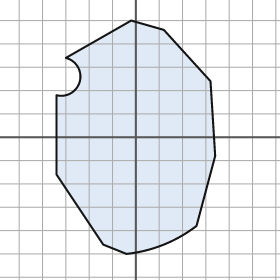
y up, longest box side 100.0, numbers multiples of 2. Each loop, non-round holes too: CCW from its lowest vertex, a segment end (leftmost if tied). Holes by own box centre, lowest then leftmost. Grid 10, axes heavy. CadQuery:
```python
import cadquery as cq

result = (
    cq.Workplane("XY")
    .moveTo(-4.0, -50.0)
    .threePointArc((12.0, -46.0), (26.0, -38.0))
    .lineTo(34.0, -8.0)
    .lineTo(32.0, 24.0)
    .lineTo(12.0, 46.0)
    .lineTo(-2.0, 50.0)
    .lineTo(-30.0, 34.0)
    .threePointArc((-24.0, 24.0), (-34.0, 18.0))
    .lineTo(-34.0, -16.0)
    .lineTo(-14.0, -46.0)
    .close()
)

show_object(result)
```